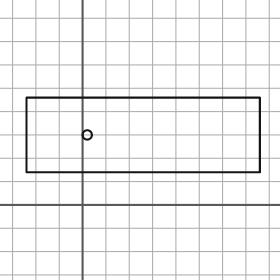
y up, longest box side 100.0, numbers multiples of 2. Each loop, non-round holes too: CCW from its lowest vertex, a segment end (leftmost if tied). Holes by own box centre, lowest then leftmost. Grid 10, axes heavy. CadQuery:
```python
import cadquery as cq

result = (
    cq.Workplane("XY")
    .moveTo(-24.0, 14.0)
    .lineTo(76.0, 14.0)
    .lineTo(76.0, 46.0)
    .lineTo(-24.0, 46.0)
    .close()
    .moveTo(2.0, 30.0)
    .circle(2.0)
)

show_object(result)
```